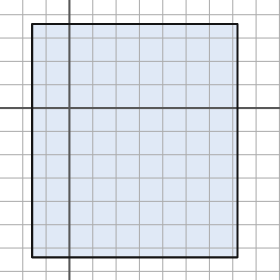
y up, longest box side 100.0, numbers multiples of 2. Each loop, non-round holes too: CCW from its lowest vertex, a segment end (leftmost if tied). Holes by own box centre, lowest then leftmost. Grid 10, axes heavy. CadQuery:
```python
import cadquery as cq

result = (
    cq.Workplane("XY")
    .moveTo(-16.0, -64.0)
    .lineTo(72.0, -64.0)
    .lineTo(72.0, 36.0)
    .lineTo(-16.0, 36.0)
    .close()
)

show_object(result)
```